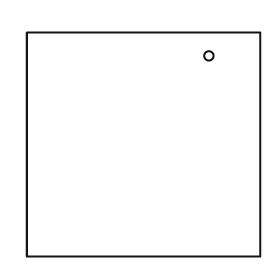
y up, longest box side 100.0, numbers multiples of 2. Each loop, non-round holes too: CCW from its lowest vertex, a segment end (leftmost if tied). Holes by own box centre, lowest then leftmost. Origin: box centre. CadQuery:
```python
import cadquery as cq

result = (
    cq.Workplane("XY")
    .moveTo(-50.0, -48.0)
    .lineTo(50.0, -48.0)
    .lineTo(50.0, 48.0)
    .lineTo(-50.0, 48.0)
    .close()
    .moveTo(28.0, 38.0)
    .circle(2.0)
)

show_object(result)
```